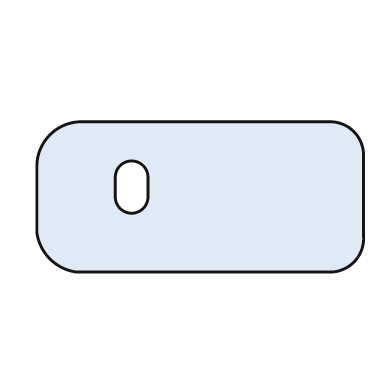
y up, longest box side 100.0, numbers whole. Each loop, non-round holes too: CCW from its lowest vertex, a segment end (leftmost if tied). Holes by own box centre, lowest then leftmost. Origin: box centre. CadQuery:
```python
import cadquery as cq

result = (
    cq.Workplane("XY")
    .moveTo(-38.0, -23.0)
    .lineTo(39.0, -23.0)
    .threePointArc((47.0, -20.0), (50.0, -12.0))
    .lineTo(50.0, 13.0)
    .threePointArc((47.0, 20.0), (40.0, 23.0))
    .lineTo(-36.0, 23.0)
    .threePointArc((-46.0, 19.0), (-50.0, 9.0))
    .lineTo(-50.0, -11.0)
    .threePointArc((-46.0, -19.0), (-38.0, -23.0))
    .close()
    .moveTo(-26.0, 0.0)
    .threePointArc((-21.0, -5.0), (-16.0, 0.0))
    .lineTo(-16.0, 6.0)
    .threePointArc((-21.0, 11.0), (-26.0, 6.0))
    .close()
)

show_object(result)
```